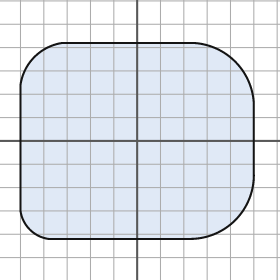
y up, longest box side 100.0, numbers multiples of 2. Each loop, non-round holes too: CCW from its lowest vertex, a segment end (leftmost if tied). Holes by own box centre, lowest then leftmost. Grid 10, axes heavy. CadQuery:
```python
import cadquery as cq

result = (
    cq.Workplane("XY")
    .moveTo(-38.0, -42.0)
    .lineTo(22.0, -42.0)
    .threePointArc((42.0, -34.0), (50.0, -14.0))
    .lineTo(50.0, 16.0)
    .threePointArc((42.0, 34.0), (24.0, 42.0))
    .lineTo(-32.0, 42.0)
    .threePointArc((-44.0, 36.0), (-50.0, 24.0))
    .lineTo(-50.0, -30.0)
    .threePointArc((-46.0, -38.0), (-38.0, -42.0))
    .close()
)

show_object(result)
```